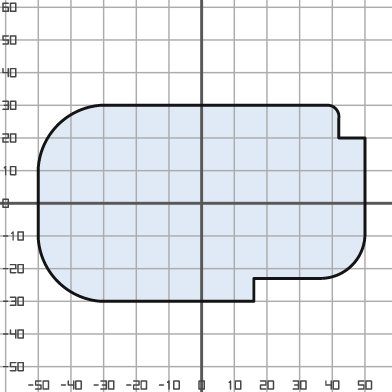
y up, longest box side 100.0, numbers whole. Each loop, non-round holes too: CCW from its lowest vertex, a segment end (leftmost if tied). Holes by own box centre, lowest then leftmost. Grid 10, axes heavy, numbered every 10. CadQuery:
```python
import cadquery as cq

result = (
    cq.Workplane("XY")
    .moveTo(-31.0, -30.0)
    .lineTo(16.0, -30.0)
    .lineTo(16.0, -23.0)
    .lineTo(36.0, -23.0)
    .threePointArc((46.0, -19.0), (50.0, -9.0))
    .lineTo(50.0, 20.0)
    .lineTo(42.0, 20.0)
    .lineTo(42.0, 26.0)
    .threePointArc((41.0, 29.0), (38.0, 30.0))
    .lineTo(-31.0, 30.0)
    .threePointArc((-44.0, 24.0), (-50.0, 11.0))
    .lineTo(-50.0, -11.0)
    .threePointArc((-44.0, -24.0), (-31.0, -30.0))
    .close()
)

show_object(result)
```